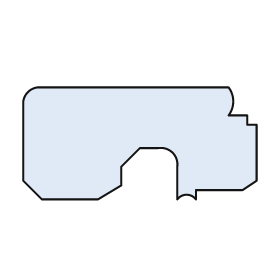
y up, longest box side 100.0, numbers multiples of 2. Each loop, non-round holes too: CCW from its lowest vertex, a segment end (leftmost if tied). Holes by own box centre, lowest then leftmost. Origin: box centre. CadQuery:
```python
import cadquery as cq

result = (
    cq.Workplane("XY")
    .moveTo(-42.0, -24.0)
    .lineTo(-18.0, -24.0)
    .lineTo(-8.0, -18.0)
    .lineTo(-8.0, -10.0)
    .lineTo(0.0, -2.0)
    .lineTo(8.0, -2.0)
    .threePointArc((14.0, -4.0), (16.0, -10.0))
    .lineTo(16.0, -24.0)
    .threePointArc((20.0, -22.0), (24.0, -24.0))
    .lineTo(24.0, -20.0)
    .lineTo(44.0, -20.0)
    .lineTo(50.0, -16.0)
    .lineTo(50.0, 8.0)
    .lineTo(46.0, 8.0)
    .lineTo(46.0, 12.0)
    .lineTo(38.0, 12.0)
    .threePointArc((40.0, 18.0), (38.0, 24.0))
    .lineTo(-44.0, 24.0)
    .threePointArc((-48.0, 22.0), (-50.0, 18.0))
    .lineTo(-50.0, -16.0)
    .close()
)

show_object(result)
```